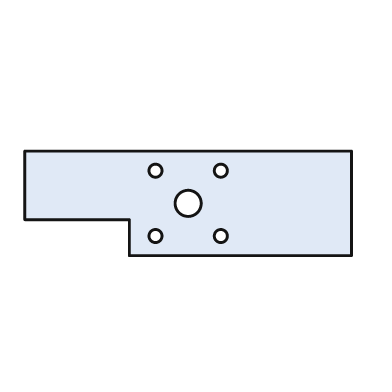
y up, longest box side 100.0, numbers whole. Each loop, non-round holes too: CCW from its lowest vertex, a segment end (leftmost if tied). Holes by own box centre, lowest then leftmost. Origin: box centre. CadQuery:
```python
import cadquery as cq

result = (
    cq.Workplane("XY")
    .moveTo(-18.0, -16.0)
    .lineTo(50.0, -16.0)
    .lineTo(50.0, 16.0)
    .lineTo(-50.0, 16.0)
    .lineTo(-50.0, -5.0)
    .lineTo(-18.0, -5.0)
    .close()
    .moveTo(-10.0, -10.0)
    .circle(2.0)
    .moveTo(10.0, -10.0)
    .circle(2.0)
    .moveTo(0.0, 0.0)
    .circle(4.0)
    .moveTo(-10.0, 10.0)
    .circle(2.0)
    .moveTo(10.0, 10.0)
    .circle(2.0)
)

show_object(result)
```